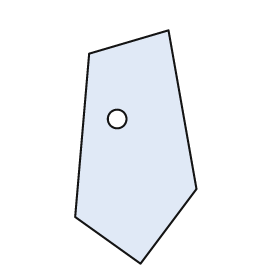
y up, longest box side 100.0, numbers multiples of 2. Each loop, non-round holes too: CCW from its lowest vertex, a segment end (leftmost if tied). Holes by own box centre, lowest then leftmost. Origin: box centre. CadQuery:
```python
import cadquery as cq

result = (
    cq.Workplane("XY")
    .moveTo(2.0, -50.0)
    .lineTo(26.0, -18.0)
    .lineTo(14.0, 50.0)
    .lineTo(-20.0, 40.0)
    .lineTo(-26.0, -30.0)
    .close()
    .moveTo(-8.0, 12.0)
    .circle(4.0)
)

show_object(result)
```